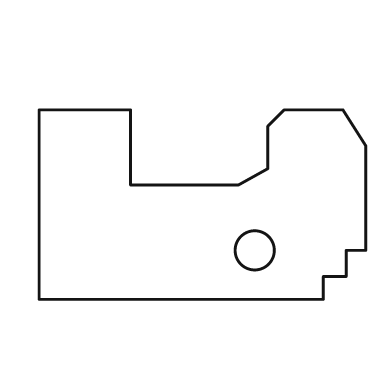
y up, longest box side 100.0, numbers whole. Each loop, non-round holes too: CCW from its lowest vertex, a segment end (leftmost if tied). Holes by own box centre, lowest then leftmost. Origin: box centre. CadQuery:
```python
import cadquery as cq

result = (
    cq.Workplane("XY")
    .moveTo(-50.0, -29.0)
    .lineTo(37.0, -29.0)
    .lineTo(37.0, -22.0)
    .lineTo(44.0, -22.0)
    .lineTo(44.0, -14.0)
    .lineTo(50.0, -14.0)
    .lineTo(50.0, 18.0)
    .lineTo(43.0, 29.0)
    .lineTo(25.0, 29.0)
    .lineTo(20.0, 24.0)
    .lineTo(20.0, 11.0)
    .lineTo(11.0, 6.0)
    .lineTo(-22.0, 6.0)
    .lineTo(-22.0, 29.0)
    .lineTo(-50.0, 29.0)
    .close()
    .moveTo(16.0, -14.0)
    .circle(6.0)
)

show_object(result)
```